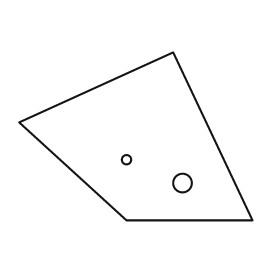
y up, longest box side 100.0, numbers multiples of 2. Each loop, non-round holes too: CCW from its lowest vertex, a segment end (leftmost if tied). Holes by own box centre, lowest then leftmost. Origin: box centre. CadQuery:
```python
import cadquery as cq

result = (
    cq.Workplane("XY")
    .moveTo(-4.0, -36.0)
    .lineTo(50.0, -36.0)
    .lineTo(16.0, 36.0)
    .lineTo(-50.0, 6.0)
    .close()
    .moveTo(20.0, -20.0)
    .circle(4.0)
    .moveTo(-4.0, -10.0)
    .circle(2.0)
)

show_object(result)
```